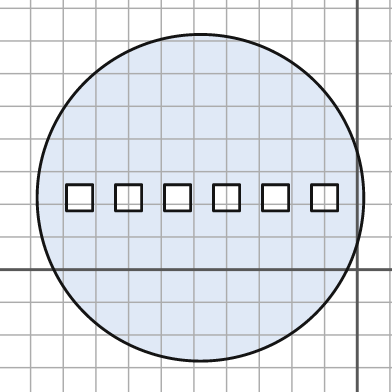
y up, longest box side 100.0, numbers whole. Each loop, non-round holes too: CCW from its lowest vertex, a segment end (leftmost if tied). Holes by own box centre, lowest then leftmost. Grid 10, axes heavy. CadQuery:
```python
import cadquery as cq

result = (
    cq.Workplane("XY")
    .moveTo(-48.0, 22.0)
    .circle(50.0)
    .moveTo(-89.0, 18.0)
    .lineTo(-81.0, 18.0)
    .lineTo(-81.0, 26.0)
    .lineTo(-89.0, 26.0)
    .close()
    .moveTo(-74.0, 18.0)
    .lineTo(-66.0, 18.0)
    .lineTo(-66.0, 26.0)
    .lineTo(-74.0, 26.0)
    .close()
    .moveTo(-59.0, 18.0)
    .lineTo(-51.0, 18.0)
    .lineTo(-51.0, 26.0)
    .lineTo(-59.0, 26.0)
    .close()
    .moveTo(-44.0, 18.0)
    .lineTo(-36.0, 18.0)
    .lineTo(-36.0, 26.0)
    .lineTo(-44.0, 26.0)
    .close()
    .moveTo(-29.0, 18.0)
    .lineTo(-21.0, 18.0)
    .lineTo(-21.0, 26.0)
    .lineTo(-29.0, 26.0)
    .close()
    .moveTo(-14.0, 18.0)
    .lineTo(-6.0, 18.0)
    .lineTo(-6.0, 26.0)
    .lineTo(-14.0, 26.0)
    .close()
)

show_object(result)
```